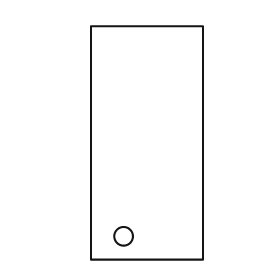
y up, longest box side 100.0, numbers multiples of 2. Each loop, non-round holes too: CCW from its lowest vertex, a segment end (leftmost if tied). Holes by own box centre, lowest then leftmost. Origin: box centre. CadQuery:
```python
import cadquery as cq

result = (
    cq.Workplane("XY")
    .moveTo(-24.0, -50.0)
    .lineTo(24.0, -50.0)
    .lineTo(24.0, 50.0)
    .lineTo(-24.0, 50.0)
    .close()
    .moveTo(-10.0, -40.0)
    .circle(4.0)
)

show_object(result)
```